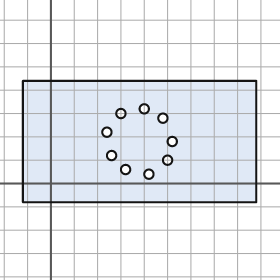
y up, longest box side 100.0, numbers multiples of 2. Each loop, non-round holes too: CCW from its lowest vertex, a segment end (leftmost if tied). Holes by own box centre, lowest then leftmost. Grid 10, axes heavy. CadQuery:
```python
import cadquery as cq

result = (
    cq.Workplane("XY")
    .moveTo(-12.0, -8.0)
    .lineTo(88.0, -8.0)
    .lineTo(88.0, 44.0)
    .lineTo(-12.0, 44.0)
    .close()
    .moveTo(42.0, 4.0)
    .circle(2.0)
    .moveTo(32.0, 6.0)
    .circle(2.0)
    .moveTo(50.0, 10.0)
    .circle(2.0)
    .moveTo(26.0, 12.0)
    .circle(2.0)
    .moveTo(52.0, 18.0)
    .circle(2.0)
    .moveTo(24.0, 22.0)
    .circle(2.0)
    .moveTo(48.0, 28.0)
    .circle(2.0)
    .moveTo(30.0, 30.0)
    .circle(2.0)
    .moveTo(40.0, 32.0)
    .circle(2.0)
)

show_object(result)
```